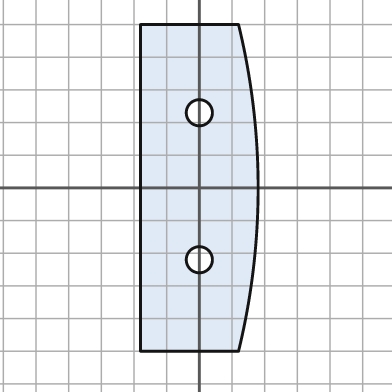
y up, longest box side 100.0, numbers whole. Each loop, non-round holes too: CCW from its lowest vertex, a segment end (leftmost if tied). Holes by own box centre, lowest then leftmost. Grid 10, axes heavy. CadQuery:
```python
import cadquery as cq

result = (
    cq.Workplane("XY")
    .moveTo(-18.0, -50.0)
    .lineTo(12.0, -50.0)
    .threePointArc((18.0, 0.0), (12.0, 50.0))
    .lineTo(-18.0, 50.0)
    .close()
    .moveTo(0.0, -22.0)
    .circle(4.0)
    .moveTo(0.0, 23.0)
    .circle(4.0)
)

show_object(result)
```